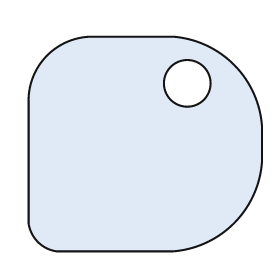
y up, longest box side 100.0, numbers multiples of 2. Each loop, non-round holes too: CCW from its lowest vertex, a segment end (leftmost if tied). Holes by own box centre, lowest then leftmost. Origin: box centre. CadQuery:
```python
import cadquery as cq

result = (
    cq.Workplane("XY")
    .moveTo(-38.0, -46.0)
    .lineTo(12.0, -46.0)
    .threePointArc((38.0, -34.0), (50.0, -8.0))
    .lineTo(50.0, 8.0)
    .threePointArc((38.0, 34.0), (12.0, 46.0))
    .lineTo(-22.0, 46.0)
    .threePointArc((-42.0, 38.0), (-50.0, 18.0))
    .lineTo(-50.0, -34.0)
    .threePointArc((-46.0, -42.0), (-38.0, -46.0))
    .close()
    .moveTo(18.0, 26.0)
    .circle(10.0)
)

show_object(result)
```